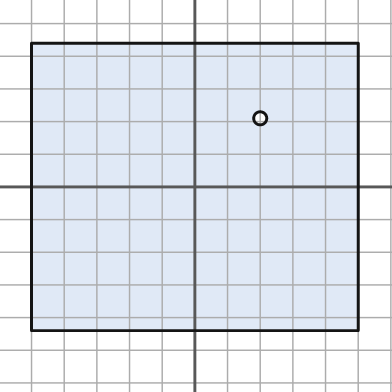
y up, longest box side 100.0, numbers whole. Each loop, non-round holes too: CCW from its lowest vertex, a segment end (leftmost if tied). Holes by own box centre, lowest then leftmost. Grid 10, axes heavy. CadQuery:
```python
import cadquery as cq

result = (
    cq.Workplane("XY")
    .moveTo(-50.0, -44.0)
    .lineTo(50.0, -44.0)
    .lineTo(50.0, 44.0)
    .lineTo(-50.0, 44.0)
    .close()
    .moveTo(20.0, 21.0)
    .circle(2.0)
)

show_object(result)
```